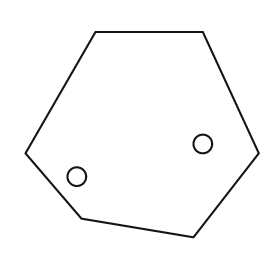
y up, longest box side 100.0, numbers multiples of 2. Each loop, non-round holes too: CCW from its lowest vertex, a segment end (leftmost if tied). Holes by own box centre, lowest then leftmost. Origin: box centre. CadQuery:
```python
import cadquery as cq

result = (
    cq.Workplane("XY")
    .moveTo(22.0, -44.0)
    .lineTo(50.0, -8.0)
    .lineTo(26.0, 44.0)
    .lineTo(-20.0, 44.0)
    .lineTo(-50.0, -8.0)
    .lineTo(-26.0, -36.0)
    .close()
    .moveTo(-28.0, -18.0)
    .circle(4.0)
    .moveTo(26.0, -4.0)
    .circle(4.0)
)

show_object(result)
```